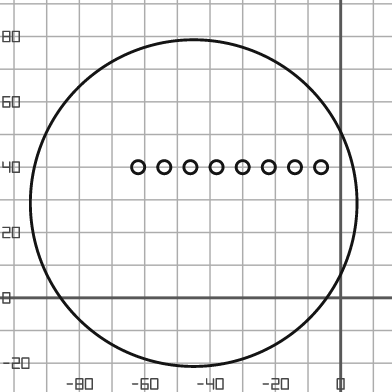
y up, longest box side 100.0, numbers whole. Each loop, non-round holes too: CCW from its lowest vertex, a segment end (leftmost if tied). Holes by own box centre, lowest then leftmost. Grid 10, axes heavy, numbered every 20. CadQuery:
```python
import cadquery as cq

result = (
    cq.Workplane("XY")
    .moveTo(-45.0, 29.0)
    .circle(50.0)
    .moveTo(-62.0, 40.0)
    .circle(2.0)
    .moveTo(-54.0, 40.0)
    .circle(2.0)
    .moveTo(-46.0, 40.0)
    .circle(2.0)
    .moveTo(-38.0, 40.0)
    .circle(2.0)
    .moveTo(-30.0, 40.0)
    .circle(2.0)
    .moveTo(-22.0, 40.0)
    .circle(2.0)
    .moveTo(-14.0, 40.0)
    .circle(2.0)
    .moveTo(-6.0, 40.0)
    .circle(2.0)
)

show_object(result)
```